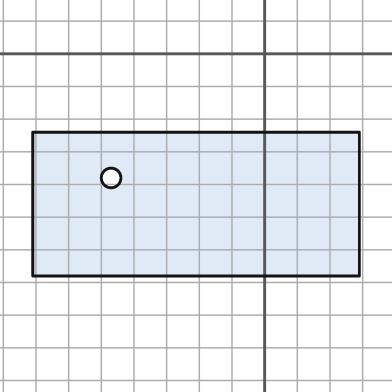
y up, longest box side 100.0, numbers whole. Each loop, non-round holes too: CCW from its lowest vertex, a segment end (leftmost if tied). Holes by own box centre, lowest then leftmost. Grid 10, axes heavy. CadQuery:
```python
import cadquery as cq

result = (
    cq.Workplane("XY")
    .moveTo(-71.0, -68.0)
    .lineTo(29.0, -68.0)
    .lineTo(29.0, -24.0)
    .lineTo(-71.0, -24.0)
    .close()
    .moveTo(-47.0, -38.0)
    .circle(3.0)
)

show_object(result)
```